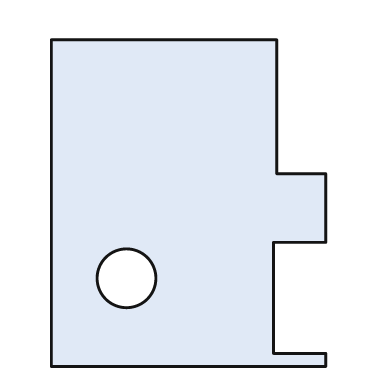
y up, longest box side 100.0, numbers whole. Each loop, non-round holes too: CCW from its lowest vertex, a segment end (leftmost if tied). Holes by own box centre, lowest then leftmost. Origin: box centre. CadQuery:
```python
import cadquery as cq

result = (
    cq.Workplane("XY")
    .moveTo(-42.0, -50.0)
    .lineTo(42.0, -50.0)
    .lineTo(42.0, -46.0)
    .lineTo(26.0, -46.0)
    .lineTo(26.0, -12.0)
    .lineTo(42.0, -12.0)
    .lineTo(42.0, 9.0)
    .lineTo(27.0, 9.0)
    .lineTo(27.0, 50.0)
    .lineTo(-42.0, 50.0)
    .close()
    .moveTo(-19.0, -23.0)
    .circle(9.0)
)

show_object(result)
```